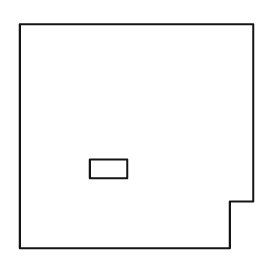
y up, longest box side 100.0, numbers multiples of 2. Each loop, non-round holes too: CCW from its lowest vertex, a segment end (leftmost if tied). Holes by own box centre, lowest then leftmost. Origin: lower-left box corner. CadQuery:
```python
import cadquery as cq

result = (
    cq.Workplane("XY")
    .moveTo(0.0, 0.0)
    .lineTo(90.0, 0.0)
    .lineTo(90.0, 20.0)
    .lineTo(100.0, 20.0)
    .lineTo(100.0, 96.0)
    .lineTo(0.0, 96.0)
    .close()
    .moveTo(30.0, 30.0)
    .lineTo(46.0, 30.0)
    .lineTo(46.0, 38.0)
    .lineTo(30.0, 38.0)
    .close()
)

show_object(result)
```